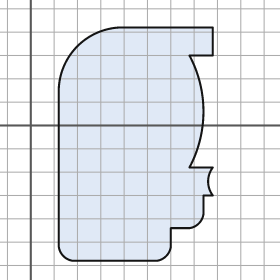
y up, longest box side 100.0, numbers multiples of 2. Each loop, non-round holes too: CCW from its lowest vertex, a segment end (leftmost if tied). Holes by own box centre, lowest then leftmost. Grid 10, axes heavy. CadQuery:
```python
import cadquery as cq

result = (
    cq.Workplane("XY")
    .moveTo(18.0, -58.0)
    .lineTo(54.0, -58.0)
    .threePointArc((58.0, -56.0), (60.0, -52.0))
    .lineTo(60.0, -44.0)
    .lineTo(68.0, -44.0)
    .threePointArc((72.0, -42.0), (74.0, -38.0))
    .lineTo(74.0, -30.0)
    .lineTo(78.0, -30.0)
    .threePointArc((76.0, -24.0), (78.0, -18.0))
    .lineTo(68.0, -18.0)
    .threePointArc((74.0, 6.0), (68.0, 30.0))
    .lineTo(78.0, 30.0)
    .lineTo(78.0, 42.0)
    .lineTo(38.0, 42.0)
    .threePointArc((20.0, 34.0), (12.0, 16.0))
    .lineTo(12.0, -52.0)
    .threePointArc((14.0, -56.0), (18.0, -58.0))
    .close()
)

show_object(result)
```